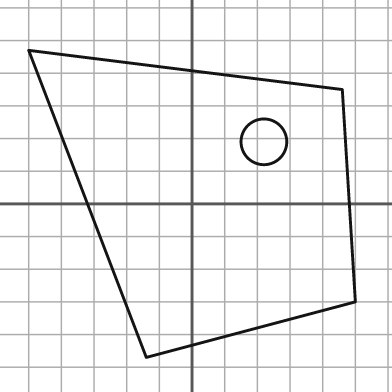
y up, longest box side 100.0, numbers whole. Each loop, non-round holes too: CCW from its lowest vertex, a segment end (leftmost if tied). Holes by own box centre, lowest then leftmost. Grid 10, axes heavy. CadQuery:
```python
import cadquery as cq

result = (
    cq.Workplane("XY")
    .moveTo(-14.0, -47.0)
    .lineTo(50.0, -30.0)
    .lineTo(46.0, 35.0)
    .lineTo(-50.0, 47.0)
    .close()
    .moveTo(22.0, 19.0)
    .circle(7.0)
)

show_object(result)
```